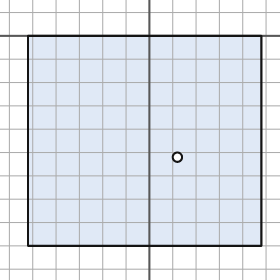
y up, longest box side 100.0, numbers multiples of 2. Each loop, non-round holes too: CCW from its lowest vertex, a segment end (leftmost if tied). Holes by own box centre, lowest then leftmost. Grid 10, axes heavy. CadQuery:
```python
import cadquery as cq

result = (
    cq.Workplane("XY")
    .moveTo(-52.0, -90.0)
    .lineTo(48.0, -90.0)
    .lineTo(48.0, 0.0)
    .lineTo(-52.0, 0.0)
    .close()
    .moveTo(12.0, -52.0)
    .circle(2.0)
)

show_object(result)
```